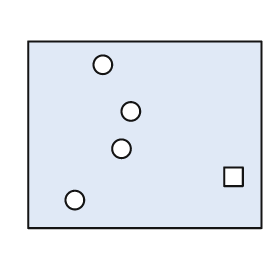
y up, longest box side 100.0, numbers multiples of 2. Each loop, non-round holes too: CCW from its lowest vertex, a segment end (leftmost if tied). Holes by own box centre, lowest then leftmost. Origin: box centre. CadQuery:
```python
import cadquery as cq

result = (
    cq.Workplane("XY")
    .moveTo(-50.0, -40.0)
    .lineTo(50.0, -40.0)
    .lineTo(50.0, 40.0)
    .lineTo(-50.0, 40.0)
    .close()
    .moveTo(-30.0, -28.0)
    .circle(4.0)
    .moveTo(34.0, -22.0)
    .lineTo(42.0, -22.0)
    .lineTo(42.0, -14.0)
    .lineTo(34.0, -14.0)
    .close()
    .moveTo(-10.0, -6.0)
    .circle(4.0)
    .moveTo(-6.0, 10.0)
    .circle(4.0)
    .moveTo(-18.0, 30.0)
    .circle(4.0)
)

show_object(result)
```